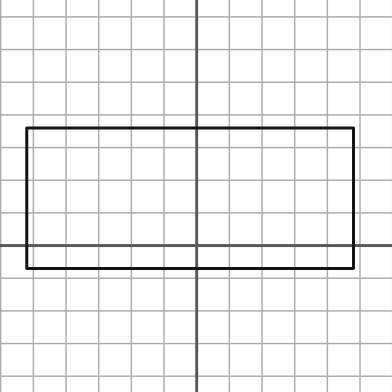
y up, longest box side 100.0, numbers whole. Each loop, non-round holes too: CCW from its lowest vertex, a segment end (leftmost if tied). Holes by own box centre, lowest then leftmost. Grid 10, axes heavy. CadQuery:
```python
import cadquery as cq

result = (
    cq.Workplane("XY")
    .moveTo(-52.0, -7.0)
    .lineTo(48.0, -7.0)
    .lineTo(48.0, 36.0)
    .lineTo(-52.0, 36.0)
    .close()
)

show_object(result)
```